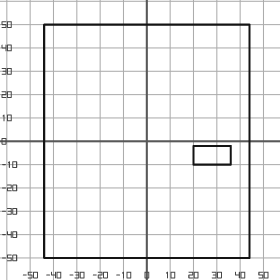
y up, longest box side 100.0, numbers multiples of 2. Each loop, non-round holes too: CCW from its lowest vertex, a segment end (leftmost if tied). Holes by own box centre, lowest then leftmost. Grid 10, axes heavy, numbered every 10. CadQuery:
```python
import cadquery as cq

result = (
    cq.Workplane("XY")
    .moveTo(-44.0, -50.0)
    .lineTo(44.0, -50.0)
    .lineTo(44.0, 50.0)
    .lineTo(-44.0, 50.0)
    .close()
    .moveTo(20.0, -10.0)
    .lineTo(36.0, -10.0)
    .lineTo(36.0, -2.0)
    .lineTo(20.0, -2.0)
    .close()
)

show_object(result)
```